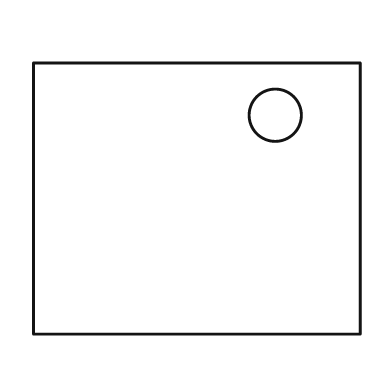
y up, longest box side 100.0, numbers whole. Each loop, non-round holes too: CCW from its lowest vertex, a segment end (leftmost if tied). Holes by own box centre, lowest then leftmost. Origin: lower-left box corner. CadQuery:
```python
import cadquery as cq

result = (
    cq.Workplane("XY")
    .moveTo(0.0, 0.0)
    .lineTo(100.0, 0.0)
    .lineTo(100.0, 83.0)
    .lineTo(0.0, 83.0)
    .close()
    .moveTo(74.0, 67.0)
    .circle(8.0)
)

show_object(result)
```